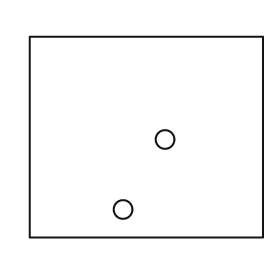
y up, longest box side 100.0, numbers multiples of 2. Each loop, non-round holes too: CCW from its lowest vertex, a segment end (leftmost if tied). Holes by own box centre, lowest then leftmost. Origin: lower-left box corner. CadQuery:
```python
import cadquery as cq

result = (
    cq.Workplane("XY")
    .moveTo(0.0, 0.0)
    .lineTo(100.0, 0.0)
    .lineTo(100.0, 86.0)
    .lineTo(0.0, 86.0)
    .close()
    .moveTo(40.0, 12.0)
    .circle(4.0)
    .moveTo(58.0, 42.0)
    .circle(4.0)
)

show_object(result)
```